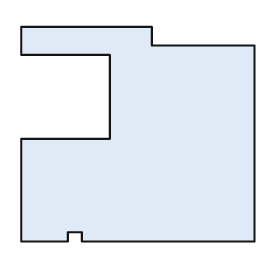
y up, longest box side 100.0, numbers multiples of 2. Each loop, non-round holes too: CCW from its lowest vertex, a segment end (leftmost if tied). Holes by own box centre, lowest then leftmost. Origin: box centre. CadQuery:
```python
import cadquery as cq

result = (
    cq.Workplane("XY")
    .moveTo(-50.0, -46.0)
    .lineTo(-30.0, -46.0)
    .lineTo(-30.0, -42.0)
    .lineTo(-24.0, -42.0)
    .lineTo(-24.0, -46.0)
    .lineTo(50.0, -46.0)
    .lineTo(50.0, 38.0)
    .lineTo(6.0, 38.0)
    .lineTo(6.0, 46.0)
    .lineTo(-50.0, 46.0)
    .lineTo(-50.0, 34.0)
    .lineTo(-12.0, 34.0)
    .lineTo(-12.0, -2.0)
    .lineTo(-50.0, -2.0)
    .close()
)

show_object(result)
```